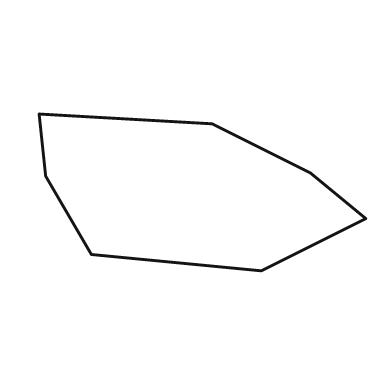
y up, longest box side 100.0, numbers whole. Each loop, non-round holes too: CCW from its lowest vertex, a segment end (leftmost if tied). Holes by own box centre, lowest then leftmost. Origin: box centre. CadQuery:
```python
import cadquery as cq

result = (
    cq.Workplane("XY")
    .moveTo(18.0, -24.0)
    .lineTo(50.0, -8.0)
    .lineTo(33.0, 6.0)
    .lineTo(3.0, 21.0)
    .lineTo(-50.0, 24.0)
    .lineTo(-48.0, 5.0)
    .lineTo(-34.0, -19.0)
    .close()
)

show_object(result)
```